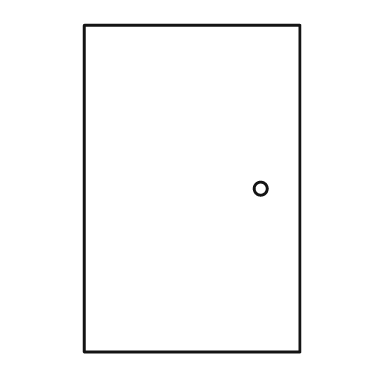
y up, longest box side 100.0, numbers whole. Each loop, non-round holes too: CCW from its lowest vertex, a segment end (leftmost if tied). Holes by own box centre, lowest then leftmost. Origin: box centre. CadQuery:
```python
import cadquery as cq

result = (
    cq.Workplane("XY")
    .moveTo(-33.0, -50.0)
    .lineTo(33.0, -50.0)
    .lineTo(33.0, 50.0)
    .lineTo(-33.0, 50.0)
    .close()
    .moveTo(21.0, 0.0)
    .circle(2.0)
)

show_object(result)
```